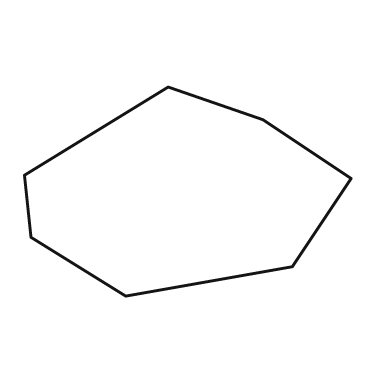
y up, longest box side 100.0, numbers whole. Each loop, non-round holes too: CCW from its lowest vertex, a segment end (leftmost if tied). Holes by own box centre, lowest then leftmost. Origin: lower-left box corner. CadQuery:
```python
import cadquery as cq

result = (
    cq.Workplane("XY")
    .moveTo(31.0, 0.0)
    .lineTo(82.0, 9.0)
    .lineTo(100.0, 36.0)
    .lineTo(73.0, 54.0)
    .lineTo(44.0, 64.0)
    .lineTo(0.0, 37.0)
    .lineTo(2.0, 18.0)
    .close()
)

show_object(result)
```